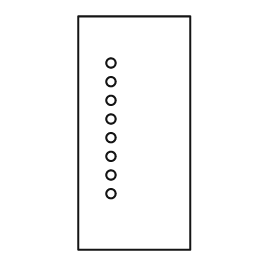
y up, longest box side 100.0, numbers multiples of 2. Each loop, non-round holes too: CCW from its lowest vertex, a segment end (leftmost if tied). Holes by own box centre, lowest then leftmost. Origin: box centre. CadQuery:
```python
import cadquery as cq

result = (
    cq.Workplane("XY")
    .moveTo(-24.0, -50.0)
    .lineTo(24.0, -50.0)
    .lineTo(24.0, 50.0)
    .lineTo(-24.0, 50.0)
    .close()
    .moveTo(-10.0, -26.0)
    .circle(2.0)
    .moveTo(-10.0, -18.0)
    .circle(2.0)
    .moveTo(-10.0, -10.0)
    .circle(2.0)
    .moveTo(-10.0, -2.0)
    .circle(2.0)
    .moveTo(-10.0, 6.0)
    .circle(2.0)
    .moveTo(-10.0, 14.0)
    .circle(2.0)
    .moveTo(-10.0, 22.0)
    .circle(2.0)
    .moveTo(-10.0, 30.0)
    .circle(2.0)
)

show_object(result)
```